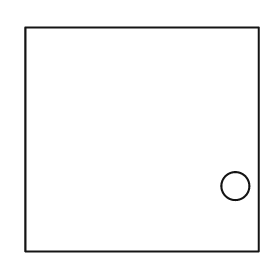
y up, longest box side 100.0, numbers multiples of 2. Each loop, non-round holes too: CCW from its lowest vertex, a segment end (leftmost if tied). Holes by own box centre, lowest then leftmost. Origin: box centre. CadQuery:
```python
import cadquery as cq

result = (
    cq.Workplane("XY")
    .moveTo(-50.0, -48.0)
    .lineTo(50.0, -48.0)
    .lineTo(50.0, 48.0)
    .lineTo(-50.0, 48.0)
    .close()
    .moveTo(40.0, -20.0)
    .circle(6.0)
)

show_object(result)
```